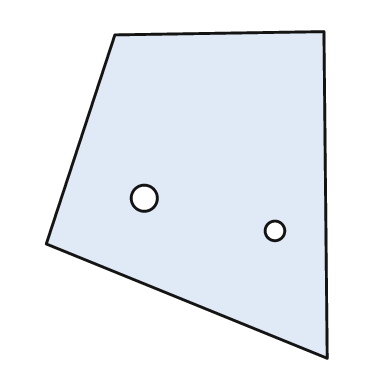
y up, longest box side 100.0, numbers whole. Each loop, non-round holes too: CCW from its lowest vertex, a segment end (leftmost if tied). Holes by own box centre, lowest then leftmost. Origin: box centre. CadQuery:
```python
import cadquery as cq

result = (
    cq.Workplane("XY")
    .moveTo(43.0, -50.0)
    .lineTo(42.0, 50.0)
    .lineTo(-22.0, 49.0)
    .lineTo(-43.0, -15.0)
    .close()
    .moveTo(27.0, -11.0)
    .circle(3.0)
    .moveTo(-13.0, -1.0)
    .circle(4.0)
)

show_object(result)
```